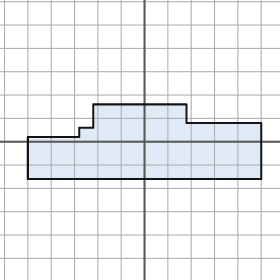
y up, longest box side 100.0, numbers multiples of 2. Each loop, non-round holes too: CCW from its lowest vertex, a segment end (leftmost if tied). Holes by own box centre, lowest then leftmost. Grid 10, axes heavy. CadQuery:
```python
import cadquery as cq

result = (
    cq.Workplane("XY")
    .moveTo(-50.0, -16.0)
    .lineTo(50.0, -16.0)
    .lineTo(50.0, 8.0)
    .lineTo(18.0, 8.0)
    .lineTo(18.0, 16.0)
    .lineTo(-22.0, 16.0)
    .lineTo(-22.0, 6.0)
    .lineTo(-28.0, 6.0)
    .lineTo(-28.0, 2.0)
    .lineTo(-50.0, 2.0)
    .close()
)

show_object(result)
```